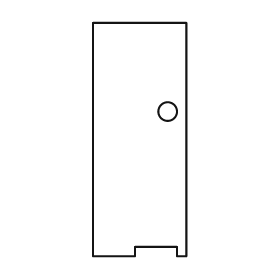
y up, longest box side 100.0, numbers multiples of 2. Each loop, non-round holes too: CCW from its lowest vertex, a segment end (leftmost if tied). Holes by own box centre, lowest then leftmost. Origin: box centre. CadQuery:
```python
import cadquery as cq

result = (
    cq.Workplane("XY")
    .moveTo(-20.0, -50.0)
    .lineTo(-2.0, -50.0)
    .lineTo(-2.0, -46.0)
    .lineTo(16.0, -46.0)
    .lineTo(16.0, -50.0)
    .lineTo(20.0, -50.0)
    .lineTo(20.0, 50.0)
    .lineTo(-20.0, 50.0)
    .close()
    .moveTo(12.0, 12.0)
    .circle(4.0)
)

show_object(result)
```